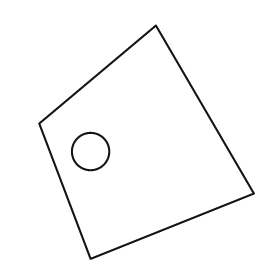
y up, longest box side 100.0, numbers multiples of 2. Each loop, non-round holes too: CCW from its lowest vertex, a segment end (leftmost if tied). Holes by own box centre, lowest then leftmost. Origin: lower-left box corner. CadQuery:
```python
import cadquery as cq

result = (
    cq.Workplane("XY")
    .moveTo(22.0, 0.0)
    .lineTo(92.0, 28.0)
    .lineTo(50.0, 100.0)
    .lineTo(0.0, 58.0)
    .close()
    .moveTo(22.0, 46.0)
    .circle(8.0)
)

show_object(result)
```